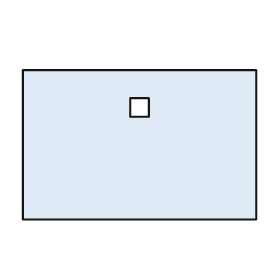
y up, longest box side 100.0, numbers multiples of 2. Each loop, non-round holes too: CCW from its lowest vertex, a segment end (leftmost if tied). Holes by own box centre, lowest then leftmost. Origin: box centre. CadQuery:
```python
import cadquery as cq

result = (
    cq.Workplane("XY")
    .moveTo(-50.0, -32.0)
    .lineTo(50.0, -32.0)
    .lineTo(50.0, 32.0)
    .lineTo(-50.0, 32.0)
    .close()
    .moveTo(-4.0, 12.0)
    .lineTo(4.0, 12.0)
    .lineTo(4.0, 20.0)
    .lineTo(-4.0, 20.0)
    .close()
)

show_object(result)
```